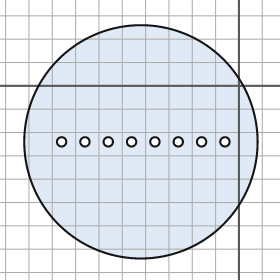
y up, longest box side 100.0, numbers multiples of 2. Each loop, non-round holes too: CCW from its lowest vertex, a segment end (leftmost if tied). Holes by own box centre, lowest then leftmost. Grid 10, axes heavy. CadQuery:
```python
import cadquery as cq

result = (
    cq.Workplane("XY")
    .moveTo(-42.0, -24.0)
    .circle(50.0)
    .moveTo(-76.0, -24.0)
    .circle(2.0)
    .moveTo(-66.0, -24.0)
    .circle(2.0)
    .moveTo(-56.0, -24.0)
    .circle(2.0)
    .moveTo(-46.0, -24.0)
    .circle(2.0)
    .moveTo(-36.0, -24.0)
    .circle(2.0)
    .moveTo(-26.0, -24.0)
    .circle(2.0)
    .moveTo(-16.0, -24.0)
    .circle(2.0)
    .moveTo(-6.0, -24.0)
    .circle(2.0)
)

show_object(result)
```